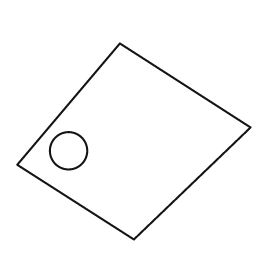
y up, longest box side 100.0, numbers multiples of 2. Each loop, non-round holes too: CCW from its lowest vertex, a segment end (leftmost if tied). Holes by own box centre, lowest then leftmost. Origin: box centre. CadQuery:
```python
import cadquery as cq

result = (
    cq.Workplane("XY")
    .moveTo(0.0, -42.0)
    .lineTo(50.0, 6.0)
    .lineTo(-6.0, 42.0)
    .lineTo(-50.0, -10.0)
    .close()
    .moveTo(-28.0, -4.0)
    .circle(8.0)
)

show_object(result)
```